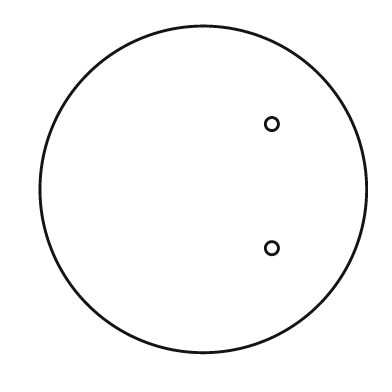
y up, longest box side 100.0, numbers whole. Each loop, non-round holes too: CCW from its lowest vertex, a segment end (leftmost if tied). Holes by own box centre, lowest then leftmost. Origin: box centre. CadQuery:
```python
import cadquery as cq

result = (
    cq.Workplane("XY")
    .moveTo(0.0, 0.0)
    .circle(50.0)
    .moveTo(21.0, -18.0)
    .circle(2.0)
    .moveTo(21.0, 20.0)
    .circle(2.0)
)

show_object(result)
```